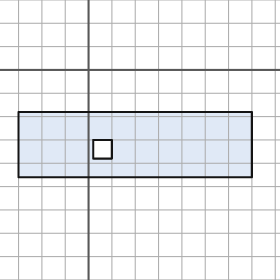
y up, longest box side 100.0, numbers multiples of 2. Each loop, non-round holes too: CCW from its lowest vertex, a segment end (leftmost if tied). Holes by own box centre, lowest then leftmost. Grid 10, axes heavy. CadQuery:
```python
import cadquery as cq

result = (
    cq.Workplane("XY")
    .moveTo(-30.0, -46.0)
    .lineTo(70.0, -46.0)
    .lineTo(70.0, -18.0)
    .lineTo(-30.0, -18.0)
    .close()
    .moveTo(2.0, -38.0)
    .lineTo(10.0, -38.0)
    .lineTo(10.0, -30.0)
    .lineTo(2.0, -30.0)
    .close()
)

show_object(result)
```